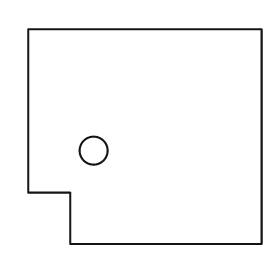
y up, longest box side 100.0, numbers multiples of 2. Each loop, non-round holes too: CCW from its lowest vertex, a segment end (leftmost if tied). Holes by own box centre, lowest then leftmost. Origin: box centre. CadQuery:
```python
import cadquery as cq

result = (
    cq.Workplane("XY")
    .moveTo(-32.0, -46.0)
    .lineTo(50.0, -46.0)
    .lineTo(50.0, 46.0)
    .lineTo(-50.0, 46.0)
    .lineTo(-50.0, -24.0)
    .lineTo(-32.0, -24.0)
    .close()
    .moveTo(-22.0, -6.0)
    .circle(6.0)
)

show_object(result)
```